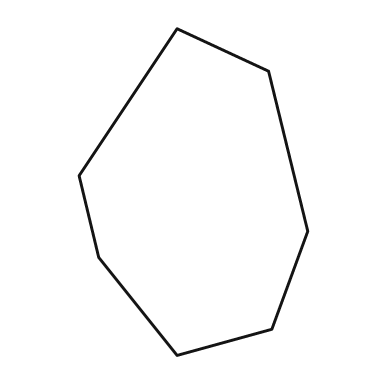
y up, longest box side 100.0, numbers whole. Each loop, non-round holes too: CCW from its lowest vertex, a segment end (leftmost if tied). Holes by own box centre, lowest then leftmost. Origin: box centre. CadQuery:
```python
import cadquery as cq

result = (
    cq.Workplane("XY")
    .moveTo(-5.0, -50.0)
    .lineTo(24.0, -42.0)
    .lineTo(35.0, -12.0)
    .lineTo(23.0, 37.0)
    .lineTo(-5.0, 50.0)
    .lineTo(-35.0, 5.0)
    .lineTo(-29.0, -20.0)
    .close()
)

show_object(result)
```